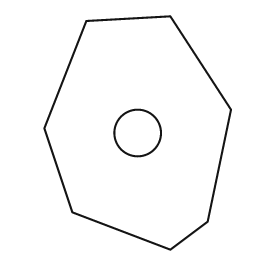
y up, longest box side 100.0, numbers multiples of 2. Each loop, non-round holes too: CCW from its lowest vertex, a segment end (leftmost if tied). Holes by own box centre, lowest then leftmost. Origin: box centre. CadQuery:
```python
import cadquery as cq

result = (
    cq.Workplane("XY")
    .moveTo(14.0, -50.0)
    .lineTo(30.0, -38.0)
    .lineTo(40.0, 10.0)
    .lineTo(14.0, 50.0)
    .lineTo(-22.0, 48.0)
    .lineTo(-40.0, 2.0)
    .lineTo(-28.0, -34.0)
    .close()
    .moveTo(0.0, 0.0)
    .circle(10.0)
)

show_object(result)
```